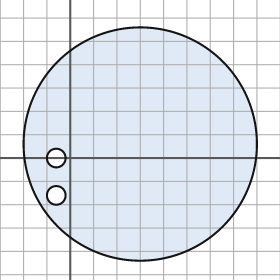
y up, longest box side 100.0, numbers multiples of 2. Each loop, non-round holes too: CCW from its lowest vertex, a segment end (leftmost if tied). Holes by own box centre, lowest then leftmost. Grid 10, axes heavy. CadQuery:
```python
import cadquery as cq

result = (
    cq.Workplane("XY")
    .moveTo(30.0, 6.0)
    .circle(50.0)
    .moveTo(-6.0, -16.0)
    .circle(4.0)
    .moveTo(-6.0, 0.0)
    .circle(4.0)
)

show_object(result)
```